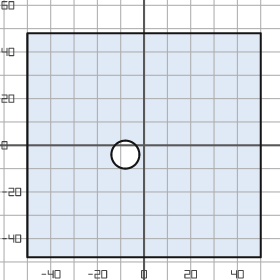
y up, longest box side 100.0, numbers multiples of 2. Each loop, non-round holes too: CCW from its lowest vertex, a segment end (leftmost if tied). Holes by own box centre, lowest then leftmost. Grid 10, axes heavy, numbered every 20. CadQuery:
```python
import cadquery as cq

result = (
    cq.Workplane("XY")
    .moveTo(-50.0, -48.0)
    .lineTo(50.0, -48.0)
    .lineTo(50.0, 48.0)
    .lineTo(-50.0, 48.0)
    .close()
    .moveTo(-8.0, -4.0)
    .circle(6.0)
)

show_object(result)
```